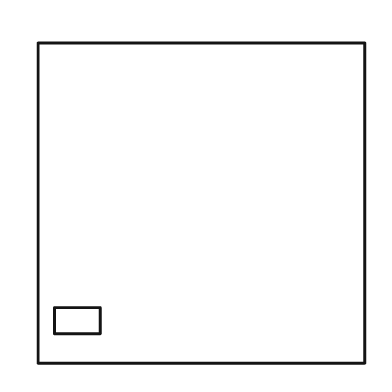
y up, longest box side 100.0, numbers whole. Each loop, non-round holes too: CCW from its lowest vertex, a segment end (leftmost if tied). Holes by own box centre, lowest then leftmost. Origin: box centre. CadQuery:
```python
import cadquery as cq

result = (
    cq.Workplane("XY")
    .moveTo(-50.0, -49.0)
    .lineTo(50.0, -49.0)
    .lineTo(50.0, 49.0)
    .lineTo(-50.0, 49.0)
    .close()
    .moveTo(-45.0, -40.0)
    .lineTo(-31.0, -40.0)
    .lineTo(-31.0, -32.0)
    .lineTo(-45.0, -32.0)
    .close()
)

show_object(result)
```